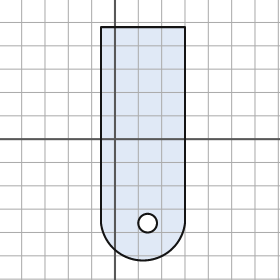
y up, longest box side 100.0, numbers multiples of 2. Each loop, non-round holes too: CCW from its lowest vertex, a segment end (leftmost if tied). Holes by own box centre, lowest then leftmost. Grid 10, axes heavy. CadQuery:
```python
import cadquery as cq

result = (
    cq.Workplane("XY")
    .moveTo(-6.0, -36.0)
    .threePointArc((12.0, -52.0), (30.0, -36.0))
    .lineTo(30.0, 48.0)
    .lineTo(-6.0, 48.0)
    .close()
    .moveTo(14.0, -36.0)
    .circle(4.0)
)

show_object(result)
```